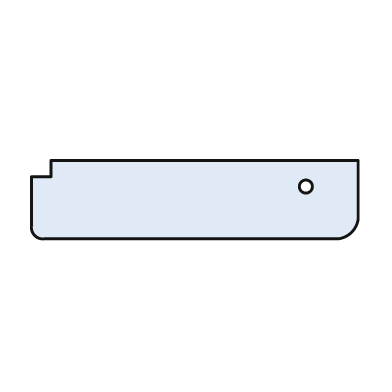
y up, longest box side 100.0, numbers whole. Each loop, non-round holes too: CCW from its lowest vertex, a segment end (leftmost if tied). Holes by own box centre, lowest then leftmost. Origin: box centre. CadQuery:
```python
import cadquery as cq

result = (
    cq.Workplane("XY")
    .moveTo(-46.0, -12.0)
    .lineTo(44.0, -12.0)
    .threePointArc((48.0, -10.0), (50.0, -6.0))
    .lineTo(50.0, 12.0)
    .lineTo(-44.0, 12.0)
    .lineTo(-44.0, 7.0)
    .lineTo(-50.0, 7.0)
    .lineTo(-50.0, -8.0)
    .threePointArc((-49.0, -11.0), (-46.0, -12.0))
    .close()
    .moveTo(34.0, 4.0)
    .circle(2.0)
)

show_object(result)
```